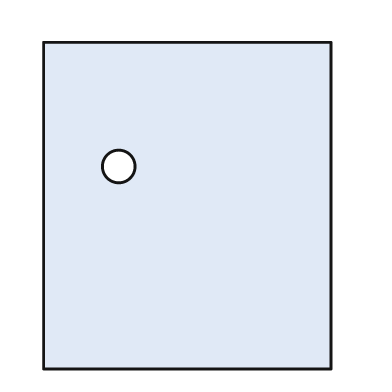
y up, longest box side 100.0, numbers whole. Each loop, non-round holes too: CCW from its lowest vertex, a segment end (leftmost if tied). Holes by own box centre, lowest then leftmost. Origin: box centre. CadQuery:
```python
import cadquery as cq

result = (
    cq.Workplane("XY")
    .moveTo(-44.0, -50.0)
    .lineTo(44.0, -50.0)
    .lineTo(44.0, 50.0)
    .lineTo(-44.0, 50.0)
    .close()
    .moveTo(-21.0, 12.0)
    .circle(5.0)
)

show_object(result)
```